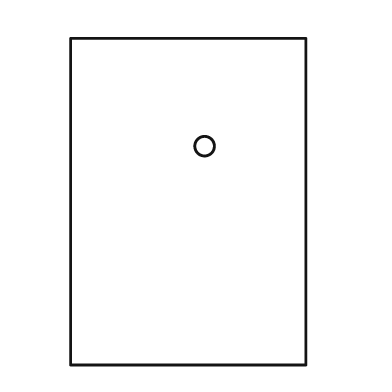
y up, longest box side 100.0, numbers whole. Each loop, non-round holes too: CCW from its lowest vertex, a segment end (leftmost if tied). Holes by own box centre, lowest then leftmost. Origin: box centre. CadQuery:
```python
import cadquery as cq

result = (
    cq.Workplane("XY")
    .moveTo(-36.0, -50.0)
    .lineTo(36.0, -50.0)
    .lineTo(36.0, 50.0)
    .lineTo(-36.0, 50.0)
    .close()
    .moveTo(5.0, 17.0)
    .circle(3.0)
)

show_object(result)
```